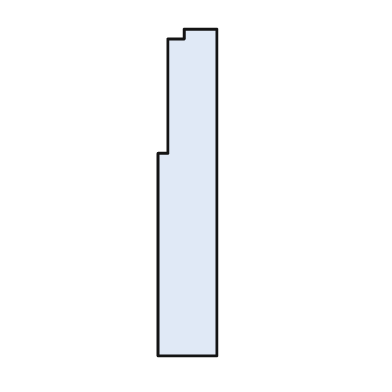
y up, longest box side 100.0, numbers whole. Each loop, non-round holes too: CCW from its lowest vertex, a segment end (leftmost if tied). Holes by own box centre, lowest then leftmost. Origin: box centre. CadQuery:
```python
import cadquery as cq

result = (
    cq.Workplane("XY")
    .moveTo(-9.0, -50.0)
    .lineTo(9.0, -50.0)
    .lineTo(9.0, 50.0)
    .lineTo(-1.0, 50.0)
    .lineTo(-1.0, 47.0)
    .lineTo(-6.0, 47.0)
    .lineTo(-6.0, 12.0)
    .lineTo(-9.0, 12.0)
    .close()
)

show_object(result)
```